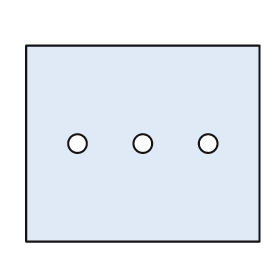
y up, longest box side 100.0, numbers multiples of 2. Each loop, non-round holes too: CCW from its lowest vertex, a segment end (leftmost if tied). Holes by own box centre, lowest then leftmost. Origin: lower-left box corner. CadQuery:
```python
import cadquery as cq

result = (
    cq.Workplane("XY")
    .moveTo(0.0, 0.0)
    .lineTo(100.0, 0.0)
    .lineTo(100.0, 84.0)
    .lineTo(0.0, 84.0)
    .close()
    .moveTo(22.0, 42.0)
    .circle(4.0)
    .moveTo(50.0, 42.0)
    .circle(4.0)
    .moveTo(78.0, 42.0)
    .circle(4.0)
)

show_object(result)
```